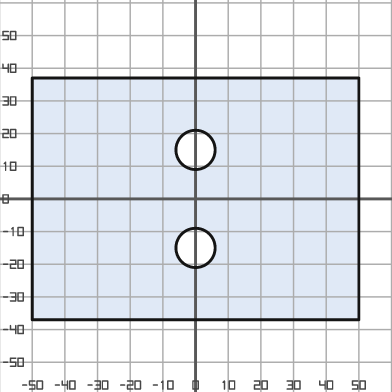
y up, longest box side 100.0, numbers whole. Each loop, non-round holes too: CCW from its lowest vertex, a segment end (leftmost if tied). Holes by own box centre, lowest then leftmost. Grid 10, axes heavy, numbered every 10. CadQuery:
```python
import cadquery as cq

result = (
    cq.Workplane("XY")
    .moveTo(-50.0, -37.0)
    .lineTo(50.0, -37.0)
    .lineTo(50.0, 37.0)
    .lineTo(-50.0, 37.0)
    .close()
    .moveTo(0.0, -15.0)
    .circle(6.0)
    .moveTo(0.0, 15.0)
    .circle(6.0)
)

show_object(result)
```